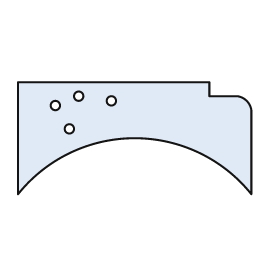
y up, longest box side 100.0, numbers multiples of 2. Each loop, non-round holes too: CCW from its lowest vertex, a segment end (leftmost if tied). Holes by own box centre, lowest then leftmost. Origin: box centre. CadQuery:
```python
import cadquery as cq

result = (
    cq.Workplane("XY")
    .moveTo(-50.0, -24.0)
    .threePointArc((0.0, 0.0), (50.0, -24.0))
    .lineTo(50.0, 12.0)
    .threePointArc((48.0, 16.0), (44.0, 18.0))
    .lineTo(32.0, 18.0)
    .lineTo(32.0, 24.0)
    .lineTo(-50.0, 24.0)
    .close()
    .moveTo(-28.0, 4.0)
    .circle(2.0)
    .moveTo(-34.0, 14.0)
    .circle(2.0)
    .moveTo(-10.0, 16.0)
    .circle(2.0)
    .moveTo(-24.0, 18.0)
    .circle(2.0)
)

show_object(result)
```